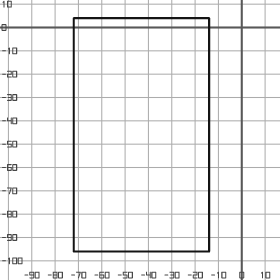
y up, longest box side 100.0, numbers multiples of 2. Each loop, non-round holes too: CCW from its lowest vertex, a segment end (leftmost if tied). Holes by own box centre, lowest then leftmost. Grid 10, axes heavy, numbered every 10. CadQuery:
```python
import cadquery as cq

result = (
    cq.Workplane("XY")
    .moveTo(-72.0, -96.0)
    .lineTo(-14.0, -96.0)
    .lineTo(-14.0, 4.0)
    .lineTo(-72.0, 4.0)
    .close()
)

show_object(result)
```